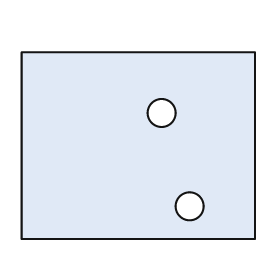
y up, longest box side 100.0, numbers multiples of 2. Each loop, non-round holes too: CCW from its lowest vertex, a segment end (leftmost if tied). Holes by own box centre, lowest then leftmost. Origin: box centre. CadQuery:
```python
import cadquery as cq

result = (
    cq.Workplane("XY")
    .moveTo(-50.0, -40.0)
    .lineTo(50.0, -40.0)
    .lineTo(50.0, 40.0)
    .lineTo(-50.0, 40.0)
    .close()
    .moveTo(22.0, -26.0)
    .circle(6.0)
    .moveTo(10.0, 14.0)
    .circle(6.0)
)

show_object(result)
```